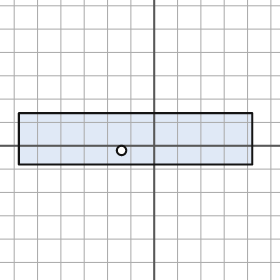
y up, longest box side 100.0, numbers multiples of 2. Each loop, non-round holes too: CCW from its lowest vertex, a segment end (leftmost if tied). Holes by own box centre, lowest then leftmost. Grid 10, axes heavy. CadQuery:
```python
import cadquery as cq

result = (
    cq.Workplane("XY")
    .moveTo(-58.0, -8.0)
    .lineTo(42.0, -8.0)
    .lineTo(42.0, 14.0)
    .lineTo(-58.0, 14.0)
    .close()
    .moveTo(-14.0, -2.0)
    .circle(2.0)
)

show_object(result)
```